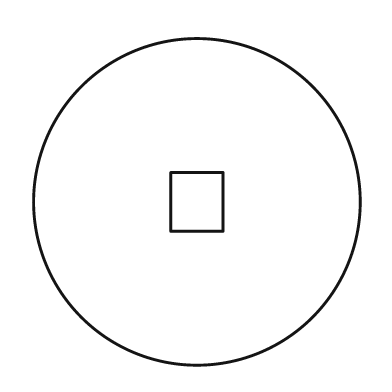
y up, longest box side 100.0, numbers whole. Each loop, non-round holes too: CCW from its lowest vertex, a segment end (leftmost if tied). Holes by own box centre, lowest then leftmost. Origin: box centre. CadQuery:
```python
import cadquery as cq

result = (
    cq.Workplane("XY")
    .moveTo(0.0, 0.0)
    .circle(50.0)
    .moveTo(-8.0, -9.0)
    .lineTo(8.0, -9.0)
    .lineTo(8.0, 9.0)
    .lineTo(-8.0, 9.0)
    .close()
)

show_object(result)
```